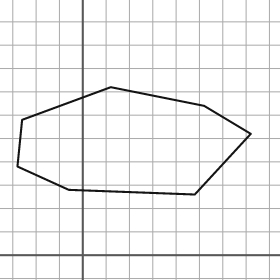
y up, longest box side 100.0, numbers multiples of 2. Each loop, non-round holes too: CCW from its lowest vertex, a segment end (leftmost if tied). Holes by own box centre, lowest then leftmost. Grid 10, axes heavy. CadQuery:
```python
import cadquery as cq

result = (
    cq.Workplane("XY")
    .moveTo(48.0, 26.0)
    .lineTo(72.0, 52.0)
    .lineTo(52.0, 64.0)
    .lineTo(12.0, 72.0)
    .lineTo(-26.0, 58.0)
    .lineTo(-28.0, 38.0)
    .lineTo(-6.0, 28.0)
    .close()
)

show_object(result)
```